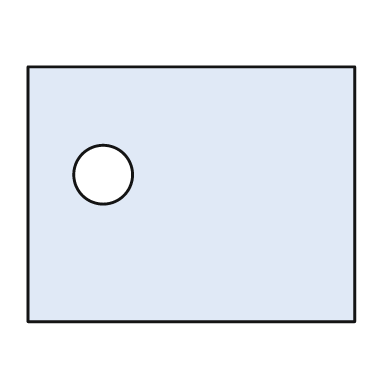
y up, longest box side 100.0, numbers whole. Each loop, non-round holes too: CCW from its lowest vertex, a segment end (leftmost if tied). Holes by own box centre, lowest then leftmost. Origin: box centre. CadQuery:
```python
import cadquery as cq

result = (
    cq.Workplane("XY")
    .moveTo(-50.0, -39.0)
    .lineTo(50.0, -39.0)
    .lineTo(50.0, 39.0)
    .lineTo(-50.0, 39.0)
    .close()
    .moveTo(-27.0, 6.0)
    .circle(9.0)
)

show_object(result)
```